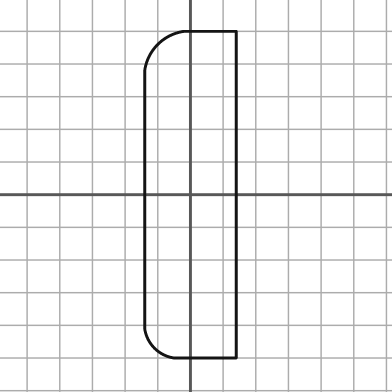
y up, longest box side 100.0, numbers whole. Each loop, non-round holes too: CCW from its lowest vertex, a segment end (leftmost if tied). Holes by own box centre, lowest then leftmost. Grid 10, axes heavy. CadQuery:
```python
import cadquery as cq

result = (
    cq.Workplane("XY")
    .moveTo(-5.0, -50.0)
    .lineTo(14.0, -50.0)
    .lineTo(14.0, 50.0)
    .lineTo(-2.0, 50.0)
    .threePointArc((-10.0, 46.0), (-14.0, 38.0))
    .lineTo(-14.0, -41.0)
    .threePointArc((-11.0, -47.0), (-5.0, -50.0))
    .close()
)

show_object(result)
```